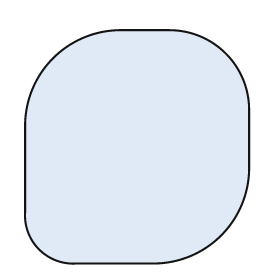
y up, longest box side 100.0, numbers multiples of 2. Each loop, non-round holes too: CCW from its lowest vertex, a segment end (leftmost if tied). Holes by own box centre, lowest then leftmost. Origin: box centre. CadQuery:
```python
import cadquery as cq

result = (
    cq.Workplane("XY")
    .moveTo(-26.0, -50.0)
    .lineTo(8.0, -50.0)
    .threePointArc((36.0, -38.0), (48.0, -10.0))
    .lineTo(48.0, 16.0)
    .threePointArc((38.0, 40.0), (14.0, 50.0))
    .lineTo(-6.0, 50.0)
    .threePointArc((-36.0, 38.0), (-48.0, 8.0))
    .lineTo(-48.0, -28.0)
    .threePointArc((-42.0, -44.0), (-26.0, -50.0))
    .close()
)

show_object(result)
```